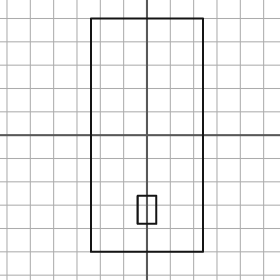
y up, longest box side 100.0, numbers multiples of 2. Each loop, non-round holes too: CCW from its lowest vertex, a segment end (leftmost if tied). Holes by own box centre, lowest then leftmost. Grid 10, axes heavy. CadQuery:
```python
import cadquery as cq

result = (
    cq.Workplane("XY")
    .moveTo(-24.0, -50.0)
    .lineTo(24.0, -50.0)
    .lineTo(24.0, 50.0)
    .lineTo(-24.0, 50.0)
    .close()
    .moveTo(-4.0, -38.0)
    .lineTo(4.0, -38.0)
    .lineTo(4.0, -26.0)
    .lineTo(-4.0, -26.0)
    .close()
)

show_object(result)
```